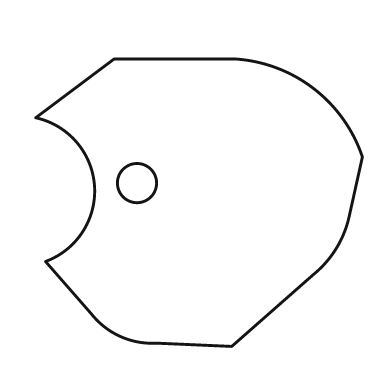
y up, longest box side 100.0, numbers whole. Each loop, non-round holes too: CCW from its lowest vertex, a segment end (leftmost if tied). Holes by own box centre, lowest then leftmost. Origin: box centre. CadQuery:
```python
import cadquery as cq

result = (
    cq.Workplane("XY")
    .moveTo(10.0, -44.0)
    .lineTo(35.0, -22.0)
    .threePointArc((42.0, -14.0), (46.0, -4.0))
    .lineTo(50.0, 14.0)
    .threePointArc((35.0, 35.0), (11.0, 44.0))
    .lineTo(-26.0, 44.0)
    .lineTo(-50.0, 26.0)
    .threePointArc((-32.0, 5.0), (-47.0, -18.0))
    .lineTo(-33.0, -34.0)
    .threePointArc((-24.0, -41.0), (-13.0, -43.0))
    .close()
    .moveTo(-19.0, 6.0)
    .circle(6.0)
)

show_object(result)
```